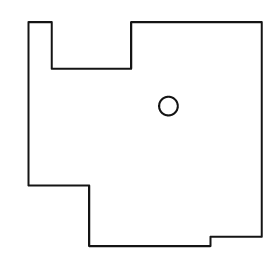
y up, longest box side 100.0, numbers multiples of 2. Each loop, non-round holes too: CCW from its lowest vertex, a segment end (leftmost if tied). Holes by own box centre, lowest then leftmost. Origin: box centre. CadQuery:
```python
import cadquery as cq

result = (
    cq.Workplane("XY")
    .moveTo(-24.0, -48.0)
    .lineTo(28.0, -48.0)
    .lineTo(28.0, -44.0)
    .lineTo(50.0, -44.0)
    .lineTo(50.0, 48.0)
    .lineTo(-6.0, 48.0)
    .lineTo(-6.0, 28.0)
    .lineTo(-40.0, 28.0)
    .lineTo(-40.0, 48.0)
    .lineTo(-50.0, 48.0)
    .lineTo(-50.0, -22.0)
    .lineTo(-24.0, -22.0)
    .close()
    .moveTo(10.0, 12.0)
    .circle(4.0)
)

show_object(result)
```